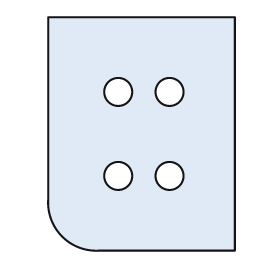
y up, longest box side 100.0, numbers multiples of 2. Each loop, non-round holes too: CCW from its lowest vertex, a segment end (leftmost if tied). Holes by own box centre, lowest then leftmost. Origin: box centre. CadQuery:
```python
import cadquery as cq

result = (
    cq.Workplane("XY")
    .moveTo(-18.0, -50.0)
    .lineTo(40.0, -50.0)
    .lineTo(40.0, 50.0)
    .lineTo(-40.0, 50.0)
    .lineTo(-40.0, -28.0)
    .threePointArc((-34.0, -44.0), (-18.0, -50.0))
    .close()
    .moveTo(-10.0, -18.0)
    .circle(6.0)
    .moveTo(12.0, -18.0)
    .circle(6.0)
    .moveTo(-10.0, 18.0)
    .circle(6.0)
    .moveTo(12.0, 18.0)
    .circle(6.0)
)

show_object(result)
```